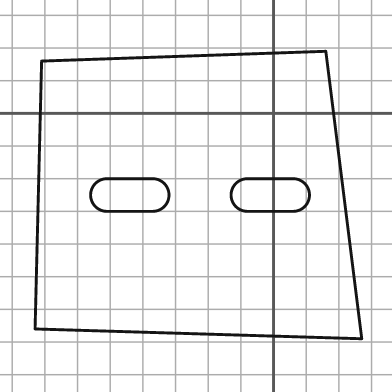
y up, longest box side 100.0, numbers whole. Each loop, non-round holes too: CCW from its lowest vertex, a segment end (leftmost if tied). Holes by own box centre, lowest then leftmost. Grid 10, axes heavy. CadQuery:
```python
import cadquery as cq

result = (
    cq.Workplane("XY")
    .moveTo(27.0, -69.0)
    .lineTo(16.0, 19.0)
    .lineTo(-71.0, 16.0)
    .lineTo(-73.0, -66.0)
    .close()
    .moveTo(-51.0, -30.0)
    .lineTo(-37.0, -30.0)
    .threePointArc((-32.0, -25.0), (-37.0, -20.0))
    .lineTo(-51.0, -20.0)
    .threePointArc((-56.0, -25.0), (-51.0, -30.0))
    .close()
    .moveTo(-8.0, -30.0)
    .lineTo(6.0, -30.0)
    .threePointArc((11.0, -25.0), (6.0, -20.0))
    .lineTo(-8.0, -20.0)
    .threePointArc((-13.0, -25.0), (-8.0, -30.0))
    .close()
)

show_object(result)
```